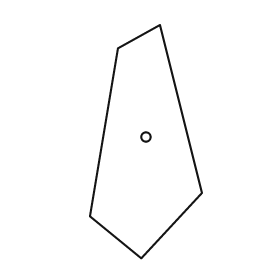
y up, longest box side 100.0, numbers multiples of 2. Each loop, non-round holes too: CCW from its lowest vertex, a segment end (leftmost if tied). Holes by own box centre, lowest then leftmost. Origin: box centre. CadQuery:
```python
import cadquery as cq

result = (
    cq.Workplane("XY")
    .moveTo(-2.0, -50.0)
    .lineTo(24.0, -22.0)
    .lineTo(6.0, 50.0)
    .lineTo(-12.0, 40.0)
    .lineTo(-24.0, -32.0)
    .close()
    .moveTo(0.0, 2.0)
    .circle(2.0)
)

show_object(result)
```